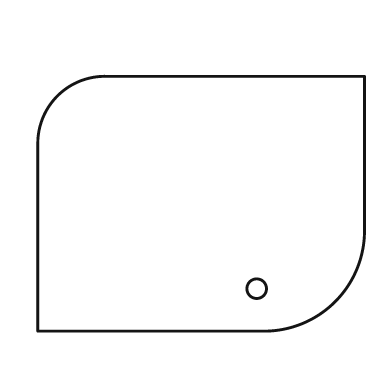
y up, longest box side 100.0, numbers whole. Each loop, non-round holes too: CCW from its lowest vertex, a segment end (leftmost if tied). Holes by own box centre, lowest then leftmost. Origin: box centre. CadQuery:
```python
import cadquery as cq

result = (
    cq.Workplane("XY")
    .moveTo(-50.0, -39.0)
    .lineTo(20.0, -39.0)
    .threePointArc((41.0, -30.0), (50.0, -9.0))
    .lineTo(50.0, 39.0)
    .lineTo(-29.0, 39.0)
    .threePointArc((-44.0, 33.0), (-50.0, 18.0))
    .close()
    .moveTo(17.0, -26.0)
    .circle(3.0)
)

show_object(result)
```